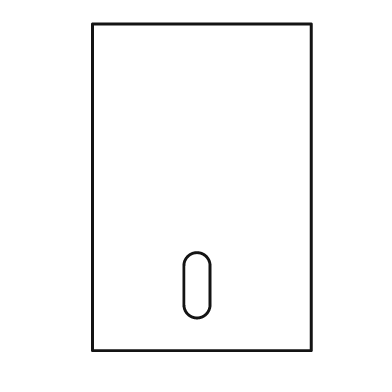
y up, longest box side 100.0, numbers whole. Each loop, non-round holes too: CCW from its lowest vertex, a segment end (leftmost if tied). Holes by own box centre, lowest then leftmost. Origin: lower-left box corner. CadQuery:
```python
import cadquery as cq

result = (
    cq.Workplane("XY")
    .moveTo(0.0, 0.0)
    .lineTo(67.0, 0.0)
    .lineTo(67.0, 100.0)
    .lineTo(0.0, 100.0)
    .close()
    .moveTo(28.0, 14.0)
    .threePointArc((32.0, 10.0), (36.0, 14.0))
    .lineTo(36.0, 26.0)
    .threePointArc((32.0, 30.0), (28.0, 26.0))
    .close()
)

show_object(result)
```